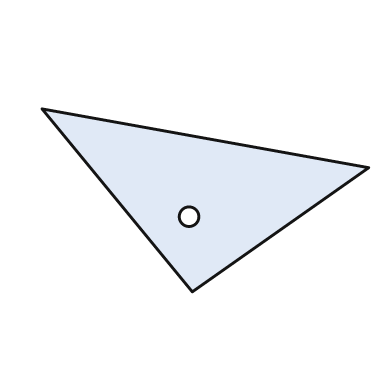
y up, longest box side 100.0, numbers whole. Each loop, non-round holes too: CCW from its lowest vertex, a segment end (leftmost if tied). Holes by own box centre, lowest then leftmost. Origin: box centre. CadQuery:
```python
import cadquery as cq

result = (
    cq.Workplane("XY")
    .moveTo(-4.0, -28.0)
    .lineTo(50.0, 10.0)
    .lineTo(-50.0, 28.0)
    .close()
    .moveTo(-5.0, -5.0)
    .circle(3.0)
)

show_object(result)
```